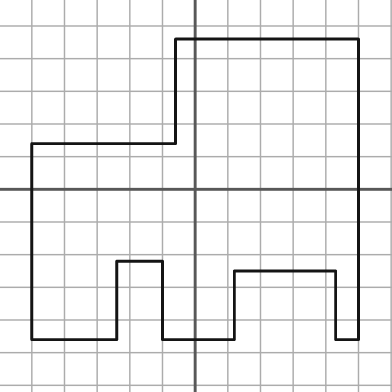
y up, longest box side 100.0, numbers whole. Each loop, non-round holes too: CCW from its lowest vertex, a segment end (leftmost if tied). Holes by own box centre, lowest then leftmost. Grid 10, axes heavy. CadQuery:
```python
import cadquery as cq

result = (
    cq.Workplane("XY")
    .moveTo(-50.0, -46.0)
    .lineTo(-24.0, -46.0)
    .lineTo(-24.0, -22.0)
    .lineTo(-10.0, -22.0)
    .lineTo(-10.0, -46.0)
    .lineTo(12.0, -46.0)
    .lineTo(12.0, -25.0)
    .lineTo(43.0, -25.0)
    .lineTo(43.0, -46.0)
    .lineTo(50.0, -46.0)
    .lineTo(50.0, 46.0)
    .lineTo(-6.0, 46.0)
    .lineTo(-6.0, 14.0)
    .lineTo(-50.0, 14.0)
    .close()
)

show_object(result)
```